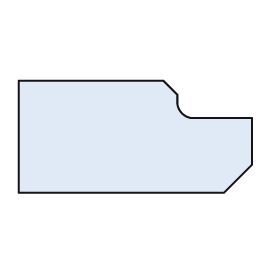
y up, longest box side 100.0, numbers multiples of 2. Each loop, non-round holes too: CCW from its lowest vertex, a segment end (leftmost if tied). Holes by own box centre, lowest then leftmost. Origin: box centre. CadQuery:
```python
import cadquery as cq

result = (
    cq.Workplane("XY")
    .moveTo(-50.0, -24.0)
    .lineTo(38.0, -24.0)
    .lineTo(50.0, -12.0)
    .lineTo(50.0, 8.0)
    .lineTo(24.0, 8.0)
    .threePointArc((20.0, 10.0), (18.0, 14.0))
    .lineTo(18.0, 18.0)
    .lineTo(12.0, 24.0)
    .lineTo(-50.0, 24.0)
    .close()
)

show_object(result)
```